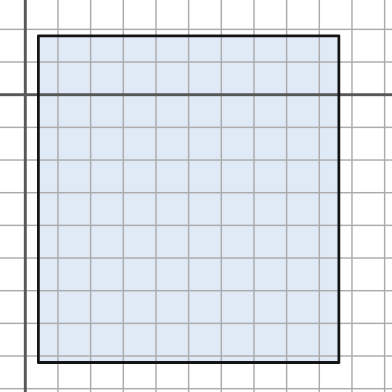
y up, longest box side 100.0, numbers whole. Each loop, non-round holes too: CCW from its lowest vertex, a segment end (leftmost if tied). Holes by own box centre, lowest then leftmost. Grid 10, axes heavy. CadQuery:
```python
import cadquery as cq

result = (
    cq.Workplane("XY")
    .moveTo(4.0, -82.0)
    .lineTo(96.0, -82.0)
    .lineTo(96.0, 18.0)
    .lineTo(4.0, 18.0)
    .close()
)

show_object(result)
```